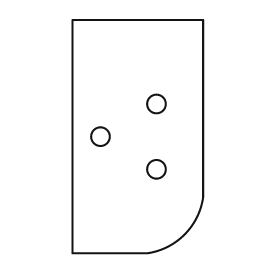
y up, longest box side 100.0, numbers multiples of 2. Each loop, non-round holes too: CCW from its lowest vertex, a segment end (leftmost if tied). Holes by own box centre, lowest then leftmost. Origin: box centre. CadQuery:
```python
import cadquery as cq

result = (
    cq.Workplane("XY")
    .moveTo(-28.0, -50.0)
    .lineTo(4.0, -50.0)
    .threePointArc((20.0, -42.0), (28.0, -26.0))
    .lineTo(28.0, 50.0)
    .lineTo(-28.0, 50.0)
    .close()
    .moveTo(8.0, -14.0)
    .circle(4.0)
    .moveTo(-16.0, 0.0)
    .circle(4.0)
    .moveTo(8.0, 14.0)
    .circle(4.0)
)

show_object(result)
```